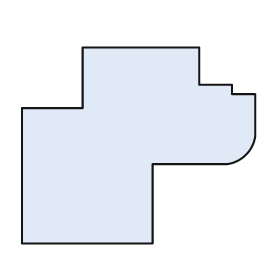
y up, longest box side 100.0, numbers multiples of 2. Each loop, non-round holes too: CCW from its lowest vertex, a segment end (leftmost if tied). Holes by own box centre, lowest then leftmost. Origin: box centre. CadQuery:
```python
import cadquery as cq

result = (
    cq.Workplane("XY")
    .moveTo(-50.0, -42.0)
    .lineTo(6.0, -42.0)
    .lineTo(6.0, -8.0)
    .lineTo(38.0, -8.0)
    .threePointArc((46.0, -4.0), (50.0, 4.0))
    .lineTo(50.0, 22.0)
    .lineTo(40.0, 22.0)
    .lineTo(40.0, 26.0)
    .lineTo(26.0, 26.0)
    .lineTo(26.0, 42.0)
    .lineTo(-24.0, 42.0)
    .lineTo(-24.0, 16.0)
    .lineTo(-50.0, 16.0)
    .close()
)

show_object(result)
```